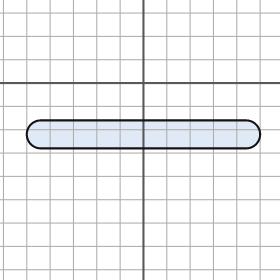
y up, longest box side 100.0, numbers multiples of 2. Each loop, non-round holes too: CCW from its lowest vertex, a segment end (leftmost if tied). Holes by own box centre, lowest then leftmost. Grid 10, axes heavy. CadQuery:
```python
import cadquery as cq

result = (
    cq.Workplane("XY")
    .moveTo(-44.0, -28.0)
    .lineTo(44.0, -28.0)
    .threePointArc((50.0, -22.0), (44.0, -16.0))
    .lineTo(-44.0, -16.0)
    .threePointArc((-50.0, -22.0), (-44.0, -28.0))
    .close()
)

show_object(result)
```